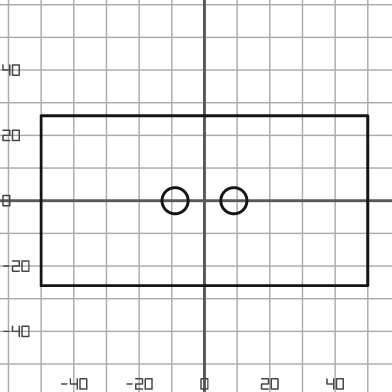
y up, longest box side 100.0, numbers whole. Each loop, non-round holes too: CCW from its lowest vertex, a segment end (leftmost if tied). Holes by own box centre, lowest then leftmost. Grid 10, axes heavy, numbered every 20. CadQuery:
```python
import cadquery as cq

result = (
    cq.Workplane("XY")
    .moveTo(-50.0, -26.0)
    .lineTo(50.0, -26.0)
    .lineTo(50.0, 26.0)
    .lineTo(-50.0, 26.0)
    .close()
    .moveTo(-9.0, 0.0)
    .circle(4.0)
    .moveTo(9.0, 0.0)
    .circle(4.0)
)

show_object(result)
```